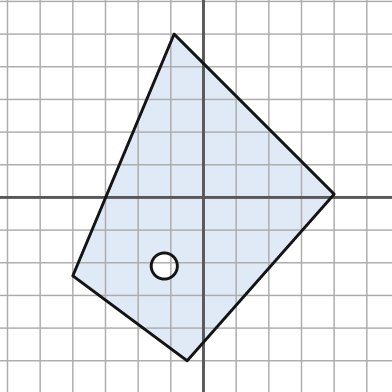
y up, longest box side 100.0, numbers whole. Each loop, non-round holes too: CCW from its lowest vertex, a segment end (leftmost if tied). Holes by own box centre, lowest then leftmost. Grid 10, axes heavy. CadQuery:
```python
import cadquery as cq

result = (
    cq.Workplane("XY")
    .moveTo(-5.0, -50.0)
    .lineTo(40.0, 1.0)
    .lineTo(-9.0, 50.0)
    .lineTo(-40.0, -24.0)
    .close()
    .moveTo(-12.0, -21.0)
    .circle(4.0)
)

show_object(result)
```